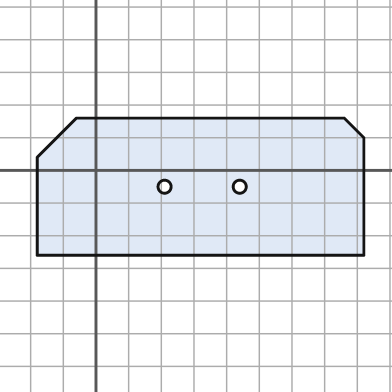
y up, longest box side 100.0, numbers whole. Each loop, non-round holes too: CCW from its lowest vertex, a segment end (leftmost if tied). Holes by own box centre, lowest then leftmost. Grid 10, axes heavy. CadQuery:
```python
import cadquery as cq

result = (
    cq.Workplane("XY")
    .moveTo(-18.0, -26.0)
    .lineTo(82.0, -26.0)
    .lineTo(82.0, 10.0)
    .lineTo(76.0, 16.0)
    .lineTo(-6.0, 16.0)
    .lineTo(-18.0, 4.0)
    .close()
    .moveTo(21.0, -5.0)
    .circle(2.0)
    .moveTo(44.0, -5.0)
    .circle(2.0)
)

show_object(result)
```